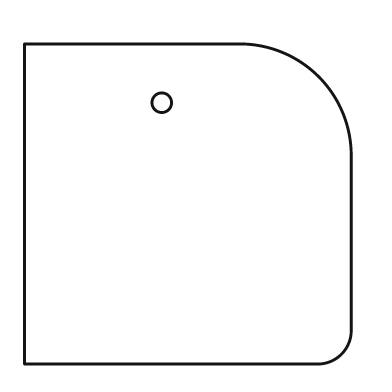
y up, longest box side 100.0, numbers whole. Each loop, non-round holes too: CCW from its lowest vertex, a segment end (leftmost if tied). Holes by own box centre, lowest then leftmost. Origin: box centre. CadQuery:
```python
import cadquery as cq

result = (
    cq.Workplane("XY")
    .moveTo(-50.0, -49.0)
    .lineTo(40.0, -49.0)
    .threePointArc((47.0, -46.0), (50.0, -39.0))
    .lineTo(50.0, 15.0)
    .threePointArc((40.0, 39.0), (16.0, 49.0))
    .lineTo(-50.0, 49.0)
    .close()
    .moveTo(-8.0, 31.0)
    .circle(3.0)
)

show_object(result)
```